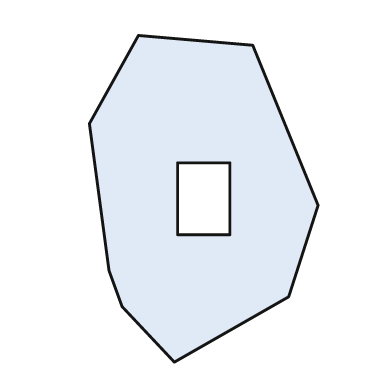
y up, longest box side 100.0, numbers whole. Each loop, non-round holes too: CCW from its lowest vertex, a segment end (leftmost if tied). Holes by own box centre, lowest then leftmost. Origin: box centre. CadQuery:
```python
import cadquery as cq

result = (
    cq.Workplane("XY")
    .moveTo(-9.0, -50.0)
    .lineTo(26.0, -30.0)
    .lineTo(35.0, -2.0)
    .lineTo(15.0, 47.0)
    .lineTo(-20.0, 50.0)
    .lineTo(-35.0, 23.0)
    .lineTo(-29.0, -22.0)
    .lineTo(-25.0, -33.0)
    .close()
    .moveTo(-8.0, -11.0)
    .lineTo(8.0, -11.0)
    .lineTo(8.0, 11.0)
    .lineTo(-8.0, 11.0)
    .close()
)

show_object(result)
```